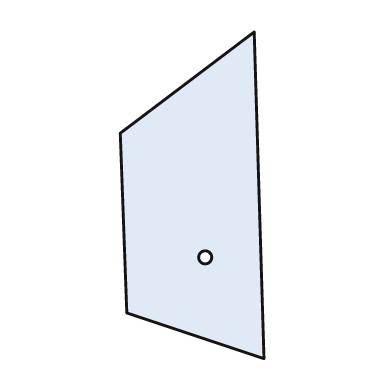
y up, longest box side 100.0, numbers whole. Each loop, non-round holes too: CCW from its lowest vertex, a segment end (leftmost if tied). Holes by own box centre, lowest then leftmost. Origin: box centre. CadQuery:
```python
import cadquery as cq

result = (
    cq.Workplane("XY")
    .moveTo(22.0, -50.0)
    .lineTo(19.0, 50.0)
    .lineTo(-22.0, 19.0)
    .lineTo(-20.0, -36.0)
    .close()
    .moveTo(4.0, -19.0)
    .circle(2.0)
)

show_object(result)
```